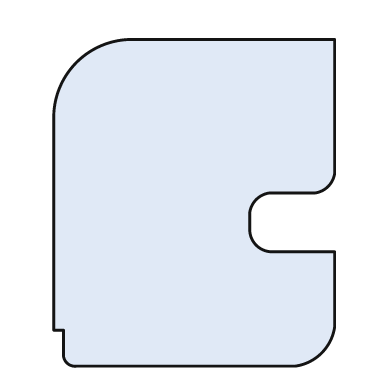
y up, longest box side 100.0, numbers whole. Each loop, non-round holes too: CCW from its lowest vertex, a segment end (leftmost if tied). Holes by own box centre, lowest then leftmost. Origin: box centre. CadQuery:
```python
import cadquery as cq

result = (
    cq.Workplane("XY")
    .moveTo(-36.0, -50.0)
    .lineTo(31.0, -50.0)
    .threePointArc((39.0, -46.0), (43.0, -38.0))
    .lineTo(43.0, -15.0)
    .lineTo(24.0, -15.0)
    .threePointArc((19.0, -13.0), (17.0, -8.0))
    .lineTo(17.0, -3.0)
    .threePointArc((19.0, 1.0), (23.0, 3.0))
    .lineTo(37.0, 3.0)
    .threePointArc((41.0, 5.0), (43.0, 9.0))
    .lineTo(43.0, 50.0)
    .lineTo(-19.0, 50.0)
    .threePointArc((-36.0, 43.0), (-43.0, 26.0))
    .lineTo(-43.0, -39.0)
    .lineTo(-40.0, -39.0)
    .lineTo(-40.0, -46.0)
    .threePointArc((-39.0, -49.0), (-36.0, -50.0))
    .close()
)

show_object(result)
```